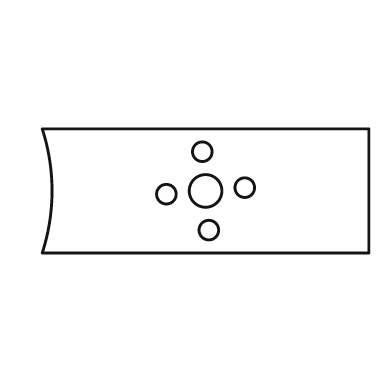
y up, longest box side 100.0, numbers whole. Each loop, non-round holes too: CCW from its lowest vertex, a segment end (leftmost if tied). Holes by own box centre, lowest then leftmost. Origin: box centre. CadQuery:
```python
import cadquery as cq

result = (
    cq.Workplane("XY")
    .moveTo(-50.0, -19.0)
    .lineTo(50.0, -19.0)
    .lineTo(50.0, 19.0)
    .lineTo(-50.0, 19.0)
    .threePointArc((-47.0, 0.0), (-50.0, -19.0))
    .close()
    .moveTo(1.0, -12.0)
    .circle(3.0)
    .moveTo(-12.0, -1.0)
    .circle(3.0)
    .moveTo(0.0, 0.0)
    .circle(5.0)
    .moveTo(12.0, 1.0)
    .circle(3.0)
    .moveTo(-1.0, 12.0)
    .circle(3.0)
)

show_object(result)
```